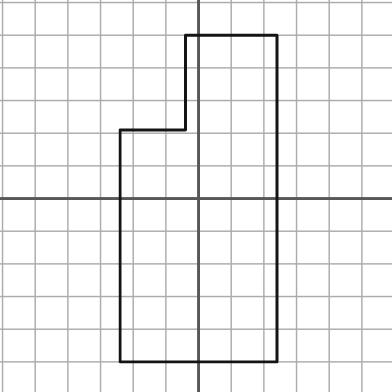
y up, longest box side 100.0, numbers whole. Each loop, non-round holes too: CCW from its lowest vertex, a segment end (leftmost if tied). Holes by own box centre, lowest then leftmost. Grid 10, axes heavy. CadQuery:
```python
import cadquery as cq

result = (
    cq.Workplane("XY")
    .moveTo(-24.0, -50.0)
    .lineTo(24.0, -50.0)
    .lineTo(24.0, 50.0)
    .lineTo(-4.0, 50.0)
    .lineTo(-4.0, 21.0)
    .lineTo(-24.0, 21.0)
    .close()
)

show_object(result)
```